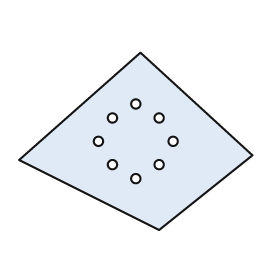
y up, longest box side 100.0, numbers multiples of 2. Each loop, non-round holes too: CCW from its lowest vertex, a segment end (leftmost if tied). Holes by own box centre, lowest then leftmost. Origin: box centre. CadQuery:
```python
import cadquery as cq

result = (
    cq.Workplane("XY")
    .moveTo(10.0, -38.0)
    .lineTo(50.0, -6.0)
    .lineTo(2.0, 38.0)
    .lineTo(-50.0, -8.0)
    .close()
    .moveTo(0.0, -16.0)
    .circle(2.0)
    .moveTo(-10.0, -10.0)
    .circle(2.0)
    .moveTo(10.0, -10.0)
    .circle(2.0)
    .moveTo(-16.0, 0.0)
    .circle(2.0)
    .moveTo(16.0, 0.0)
    .circle(2.0)
    .moveTo(-10.0, 10.0)
    .circle(2.0)
    .moveTo(10.0, 10.0)
    .circle(2.0)
    .moveTo(0.0, 16.0)
    .circle(2.0)
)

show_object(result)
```